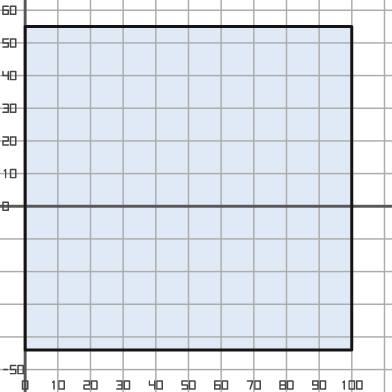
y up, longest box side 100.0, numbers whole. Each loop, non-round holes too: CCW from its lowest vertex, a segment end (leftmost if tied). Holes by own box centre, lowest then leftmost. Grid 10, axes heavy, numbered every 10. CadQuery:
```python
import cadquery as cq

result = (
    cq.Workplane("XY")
    .moveTo(0.0, -44.0)
    .lineTo(100.0, -44.0)
    .lineTo(100.0, 55.0)
    .lineTo(0.0, 55.0)
    .close()
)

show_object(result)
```